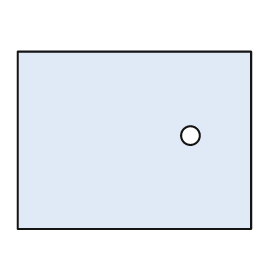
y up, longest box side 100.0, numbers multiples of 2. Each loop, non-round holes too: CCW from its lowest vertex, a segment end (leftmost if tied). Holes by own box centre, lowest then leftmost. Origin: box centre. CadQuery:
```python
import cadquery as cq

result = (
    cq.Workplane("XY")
    .moveTo(-50.0, -38.0)
    .lineTo(50.0, -38.0)
    .lineTo(50.0, 38.0)
    .lineTo(-50.0, 38.0)
    .close()
    .moveTo(24.0, 2.0)
    .circle(4.0)
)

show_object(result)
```